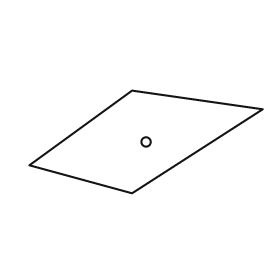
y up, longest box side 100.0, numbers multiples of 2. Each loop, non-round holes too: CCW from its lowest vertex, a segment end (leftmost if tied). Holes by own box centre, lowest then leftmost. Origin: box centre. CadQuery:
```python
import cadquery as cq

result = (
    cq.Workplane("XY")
    .moveTo(-6.0, -22.0)
    .lineTo(50.0, 14.0)
    .lineTo(-6.0, 22.0)
    .lineTo(-50.0, -10.0)
    .close()
    .moveTo(0.0, 0.0)
    .circle(2.0)
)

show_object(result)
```